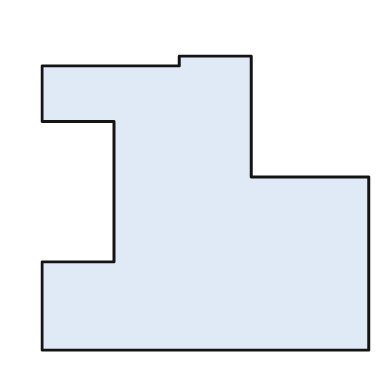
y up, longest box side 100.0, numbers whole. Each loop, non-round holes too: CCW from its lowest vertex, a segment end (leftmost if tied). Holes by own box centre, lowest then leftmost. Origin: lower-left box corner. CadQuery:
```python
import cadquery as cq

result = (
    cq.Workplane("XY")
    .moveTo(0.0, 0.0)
    .lineTo(100.0, 0.0)
    .lineTo(100.0, 53.0)
    .lineTo(64.0, 53.0)
    .lineTo(64.0, 90.0)
    .lineTo(42.0, 90.0)
    .lineTo(42.0, 87.0)
    .lineTo(0.0, 87.0)
    .lineTo(0.0, 70.0)
    .lineTo(22.0, 70.0)
    .lineTo(22.0, 27.0)
    .lineTo(0.0, 27.0)
    .close()
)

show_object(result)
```